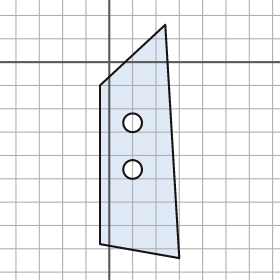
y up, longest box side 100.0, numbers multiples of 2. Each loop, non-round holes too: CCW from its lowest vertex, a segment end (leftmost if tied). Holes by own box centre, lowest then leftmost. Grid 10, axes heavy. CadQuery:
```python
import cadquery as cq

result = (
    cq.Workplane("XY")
    .moveTo(30.0, -84.0)
    .lineTo(24.0, 16.0)
    .lineTo(-4.0, -10.0)
    .lineTo(-4.0, -78.0)
    .close()
    .moveTo(10.0, -46.0)
    .circle(4.0)
    .moveTo(10.0, -26.0)
    .circle(4.0)
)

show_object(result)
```